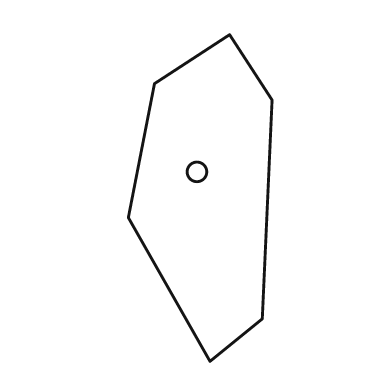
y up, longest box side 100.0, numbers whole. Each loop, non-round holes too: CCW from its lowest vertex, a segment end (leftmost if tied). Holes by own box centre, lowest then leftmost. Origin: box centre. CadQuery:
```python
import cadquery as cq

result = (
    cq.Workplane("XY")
    .moveTo(3.0, -50.0)
    .lineTo(19.0, -37.0)
    .lineTo(22.0, 30.0)
    .lineTo(9.0, 50.0)
    .lineTo(-14.0, 35.0)
    .lineTo(-22.0, -6.0)
    .close()
    .moveTo(-1.0, 8.0)
    .circle(3.0)
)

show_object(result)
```